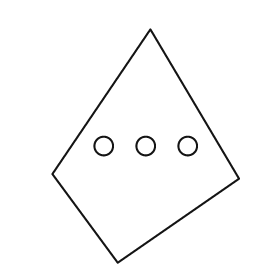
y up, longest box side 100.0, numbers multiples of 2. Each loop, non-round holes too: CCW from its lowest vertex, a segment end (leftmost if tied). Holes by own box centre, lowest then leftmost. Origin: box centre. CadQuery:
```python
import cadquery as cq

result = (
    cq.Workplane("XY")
    .moveTo(-12.0, -50.0)
    .lineTo(40.0, -14.0)
    .lineTo(2.0, 50.0)
    .lineTo(-40.0, -12.0)
    .close()
    .moveTo(-18.0, 0.0)
    .circle(4.0)
    .moveTo(0.0, 0.0)
    .circle(4.0)
    .moveTo(18.0, 0.0)
    .circle(4.0)
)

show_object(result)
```